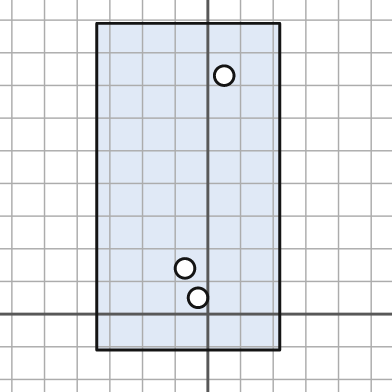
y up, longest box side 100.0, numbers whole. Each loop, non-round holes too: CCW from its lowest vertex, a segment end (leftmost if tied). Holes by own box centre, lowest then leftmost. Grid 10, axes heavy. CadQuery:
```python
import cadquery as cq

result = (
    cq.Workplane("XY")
    .moveTo(-34.0, -11.0)
    .lineTo(22.0, -11.0)
    .lineTo(22.0, 89.0)
    .lineTo(-34.0, 89.0)
    .close()
    .moveTo(-3.0, 5.0)
    .circle(3.0)
    .moveTo(-7.0, 14.0)
    .circle(3.0)
    .moveTo(5.0, 73.0)
    .circle(3.0)
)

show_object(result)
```